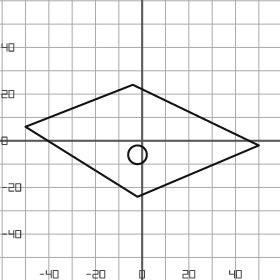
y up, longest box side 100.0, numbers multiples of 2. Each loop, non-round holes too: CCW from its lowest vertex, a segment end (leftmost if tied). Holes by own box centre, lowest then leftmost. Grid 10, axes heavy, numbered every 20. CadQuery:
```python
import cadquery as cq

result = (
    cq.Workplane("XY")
    .moveTo(-2.0, -24.0)
    .lineTo(50.0, -2.0)
    .lineTo(-4.0, 24.0)
    .lineTo(-50.0, 6.0)
    .close()
    .moveTo(-2.0, -6.0)
    .circle(4.0)
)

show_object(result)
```